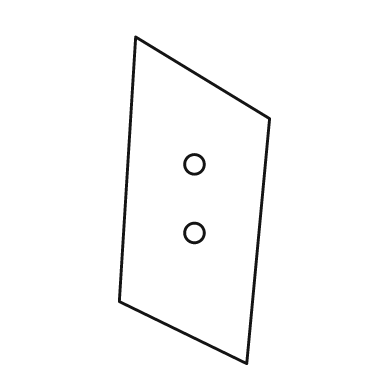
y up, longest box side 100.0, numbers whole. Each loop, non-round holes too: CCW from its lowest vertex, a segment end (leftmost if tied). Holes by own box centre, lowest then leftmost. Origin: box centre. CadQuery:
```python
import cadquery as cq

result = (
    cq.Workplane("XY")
    .moveTo(16.0, -50.0)
    .lineTo(23.0, 25.0)
    .lineTo(-18.0, 50.0)
    .lineTo(-23.0, -31.0)
    .close()
    .moveTo(0.0, -10.0)
    .circle(3.0)
    .moveTo(0.0, 11.0)
    .circle(3.0)
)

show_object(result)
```